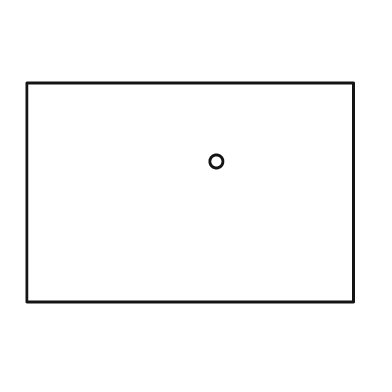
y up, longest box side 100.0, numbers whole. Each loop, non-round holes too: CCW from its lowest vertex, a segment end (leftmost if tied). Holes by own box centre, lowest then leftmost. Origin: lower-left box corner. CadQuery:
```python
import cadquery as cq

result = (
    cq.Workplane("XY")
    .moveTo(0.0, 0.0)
    .lineTo(100.0, 0.0)
    .lineTo(100.0, 67.0)
    .lineTo(0.0, 67.0)
    .close()
    .moveTo(58.0, 43.0)
    .circle(2.0)
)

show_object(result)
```